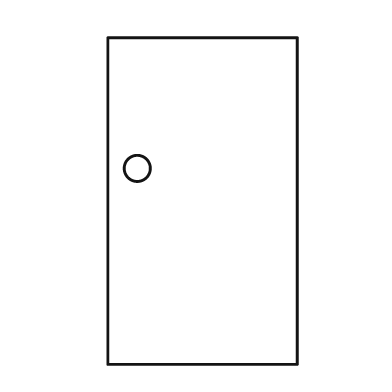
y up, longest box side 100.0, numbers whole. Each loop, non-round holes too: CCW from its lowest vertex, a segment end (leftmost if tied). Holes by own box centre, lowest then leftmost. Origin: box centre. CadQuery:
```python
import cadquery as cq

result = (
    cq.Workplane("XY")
    .moveTo(-29.0, -50.0)
    .lineTo(29.0, -50.0)
    .lineTo(29.0, 50.0)
    .lineTo(-29.0, 50.0)
    .close()
    .moveTo(-20.0, 10.0)
    .circle(4.0)
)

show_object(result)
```